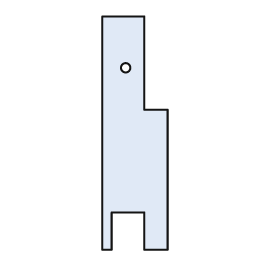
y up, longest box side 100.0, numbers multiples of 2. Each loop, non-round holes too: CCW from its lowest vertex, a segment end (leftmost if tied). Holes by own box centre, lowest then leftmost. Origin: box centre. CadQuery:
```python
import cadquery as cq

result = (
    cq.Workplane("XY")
    .moveTo(-14.0, -50.0)
    .lineTo(-10.0, -50.0)
    .lineTo(-10.0, -34.0)
    .lineTo(4.0, -34.0)
    .lineTo(4.0, -50.0)
    .lineTo(14.0, -50.0)
    .lineTo(14.0, 10.0)
    .lineTo(4.0, 10.0)
    .lineTo(4.0, 50.0)
    .lineTo(-14.0, 50.0)
    .close()
    .moveTo(-4.0, 28.0)
    .circle(2.0)
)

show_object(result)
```